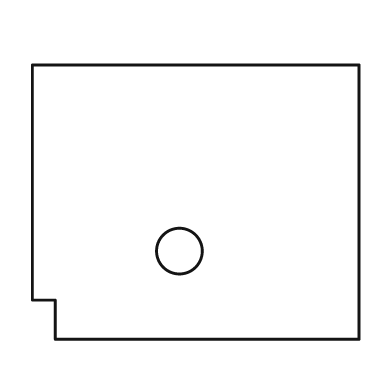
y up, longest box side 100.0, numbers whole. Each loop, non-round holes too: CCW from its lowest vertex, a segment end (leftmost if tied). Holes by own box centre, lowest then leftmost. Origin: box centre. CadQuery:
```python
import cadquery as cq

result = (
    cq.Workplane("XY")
    .moveTo(-43.0, -42.0)
    .lineTo(50.0, -42.0)
    .lineTo(50.0, 42.0)
    .lineTo(-50.0, 42.0)
    .lineTo(-50.0, -30.0)
    .lineTo(-43.0, -30.0)
    .close()
    .moveTo(-5.0, -15.0)
    .circle(7.0)
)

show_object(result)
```